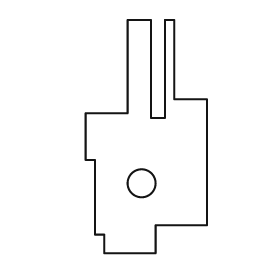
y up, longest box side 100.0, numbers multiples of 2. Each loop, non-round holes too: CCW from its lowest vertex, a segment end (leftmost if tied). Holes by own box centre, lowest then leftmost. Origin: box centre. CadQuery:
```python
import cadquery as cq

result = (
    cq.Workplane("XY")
    .moveTo(-18.0, -50.0)
    .lineTo(4.0, -50.0)
    .lineTo(4.0, -38.0)
    .lineTo(26.0, -38.0)
    .lineTo(26.0, 16.0)
    .lineTo(12.0, 16.0)
    .lineTo(12.0, 50.0)
    .lineTo(8.0, 50.0)
    .lineTo(8.0, 8.0)
    .lineTo(2.0, 8.0)
    .lineTo(2.0, 50.0)
    .lineTo(-8.0, 50.0)
    .lineTo(-8.0, 10.0)
    .lineTo(-26.0, 10.0)
    .lineTo(-26.0, -10.0)
    .lineTo(-22.0, -10.0)
    .lineTo(-22.0, -42.0)
    .lineTo(-18.0, -42.0)
    .close()
    .moveTo(-2.0, -20.0)
    .circle(6.0)
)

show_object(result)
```